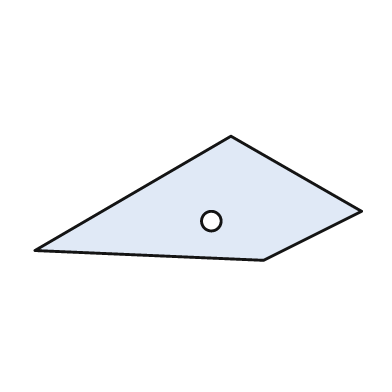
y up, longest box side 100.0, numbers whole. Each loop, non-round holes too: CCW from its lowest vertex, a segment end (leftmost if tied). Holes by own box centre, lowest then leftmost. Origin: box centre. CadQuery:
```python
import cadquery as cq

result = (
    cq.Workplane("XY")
    .moveTo(20.0, -19.0)
    .lineTo(50.0, -4.0)
    .lineTo(10.0, 19.0)
    .lineTo(-50.0, -16.0)
    .close()
    .moveTo(4.0, -7.0)
    .circle(3.0)
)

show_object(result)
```